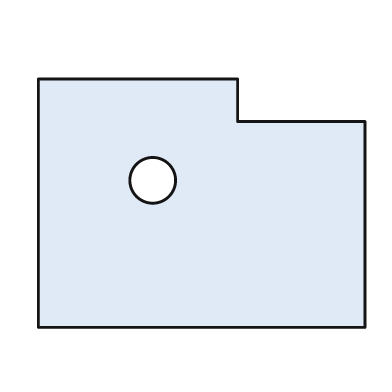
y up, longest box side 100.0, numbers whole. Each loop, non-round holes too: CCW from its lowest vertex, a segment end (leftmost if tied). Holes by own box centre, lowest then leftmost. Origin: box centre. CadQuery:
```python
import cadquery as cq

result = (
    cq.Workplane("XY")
    .moveTo(-50.0, -38.0)
    .lineTo(50.0, -38.0)
    .lineTo(50.0, 25.0)
    .lineTo(11.0, 25.0)
    .lineTo(11.0, 38.0)
    .lineTo(-50.0, 38.0)
    .close()
    .moveTo(-15.0, 7.0)
    .circle(7.0)
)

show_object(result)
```